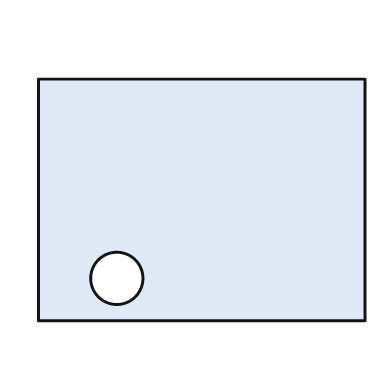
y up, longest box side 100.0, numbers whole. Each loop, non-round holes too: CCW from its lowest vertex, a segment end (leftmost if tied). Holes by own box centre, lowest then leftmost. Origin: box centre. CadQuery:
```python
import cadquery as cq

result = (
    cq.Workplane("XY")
    .moveTo(-50.0, -37.0)
    .lineTo(50.0, -37.0)
    .lineTo(50.0, 37.0)
    .lineTo(-50.0, 37.0)
    .close()
    .moveTo(-26.0, -24.0)
    .circle(8.0)
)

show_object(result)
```